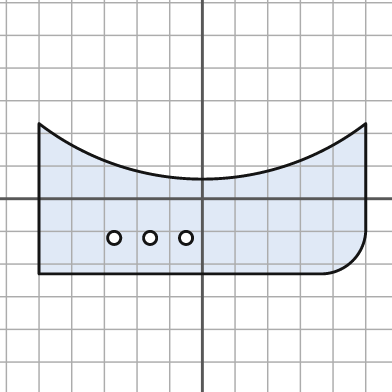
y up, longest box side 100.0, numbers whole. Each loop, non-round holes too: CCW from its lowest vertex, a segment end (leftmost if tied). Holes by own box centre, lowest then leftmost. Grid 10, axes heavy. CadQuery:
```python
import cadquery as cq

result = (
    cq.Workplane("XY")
    .moveTo(-50.0, -23.0)
    .lineTo(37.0, -23.0)
    .threePointArc((46.0, -19.0), (50.0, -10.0))
    .lineTo(50.0, 23.0)
    .threePointArc((0.0, 6.0), (-50.0, 23.0))
    .close()
    .moveTo(-27.0, -12.0)
    .circle(2.0)
    .moveTo(-16.0, -12.0)
    .circle(2.0)
    .moveTo(-5.0, -12.0)
    .circle(2.0)
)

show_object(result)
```